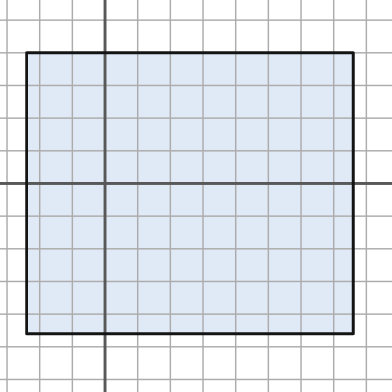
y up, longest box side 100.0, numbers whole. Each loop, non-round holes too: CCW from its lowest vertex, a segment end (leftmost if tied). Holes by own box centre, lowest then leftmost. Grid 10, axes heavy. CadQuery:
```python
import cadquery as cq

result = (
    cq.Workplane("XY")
    .moveTo(-24.0, -46.0)
    .lineTo(76.0, -46.0)
    .lineTo(76.0, 40.0)
    .lineTo(-24.0, 40.0)
    .close()
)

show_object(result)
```